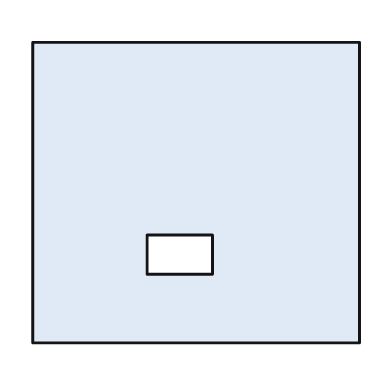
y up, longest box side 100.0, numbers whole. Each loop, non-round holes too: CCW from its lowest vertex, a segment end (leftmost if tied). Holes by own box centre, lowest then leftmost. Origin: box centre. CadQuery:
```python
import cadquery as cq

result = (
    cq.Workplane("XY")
    .moveTo(-50.0, -46.0)
    .lineTo(50.0, -46.0)
    .lineTo(50.0, 46.0)
    .lineTo(-50.0, 46.0)
    .close()
    .moveTo(-15.0, -25.0)
    .lineTo(5.0, -25.0)
    .lineTo(5.0, -13.0)
    .lineTo(-15.0, -13.0)
    .close()
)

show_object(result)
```